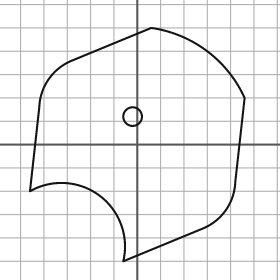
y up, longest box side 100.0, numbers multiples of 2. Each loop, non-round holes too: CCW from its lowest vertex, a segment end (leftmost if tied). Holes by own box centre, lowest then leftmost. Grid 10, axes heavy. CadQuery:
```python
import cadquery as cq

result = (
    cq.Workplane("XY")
    .moveTo(-6.0, -50.0)
    .lineTo(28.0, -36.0)
    .threePointArc((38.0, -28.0), (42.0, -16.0))
    .lineTo(46.0, 20.0)
    .threePointArc((30.0, 40.0), (6.0, 50.0))
    .lineTo(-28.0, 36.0)
    .threePointArc((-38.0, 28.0), (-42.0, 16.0))
    .lineTo(-46.0, -20.0)
    .threePointArc((-16.0, -22.0), (-6.0, -50.0))
    .close()
    .moveTo(-2.0, 12.0)
    .circle(4.0)
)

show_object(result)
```